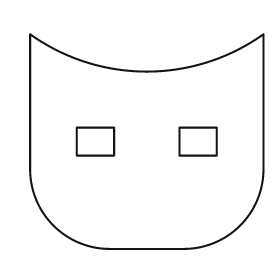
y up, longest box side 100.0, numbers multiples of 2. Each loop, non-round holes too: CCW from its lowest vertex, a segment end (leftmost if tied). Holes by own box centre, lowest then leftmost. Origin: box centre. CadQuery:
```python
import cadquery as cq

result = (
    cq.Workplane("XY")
    .moveTo(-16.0, -46.0)
    .lineTo(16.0, -46.0)
    .threePointArc((40.0, -36.0), (50.0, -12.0))
    .lineTo(50.0, 46.0)
    .threePointArc((0.0, 30.0), (-50.0, 46.0))
    .lineTo(-50.0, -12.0)
    .threePointArc((-40.0, -36.0), (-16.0, -46.0))
    .close()
    .moveTo(-30.0, -6.0)
    .lineTo(-14.0, -6.0)
    .lineTo(-14.0, 6.0)
    .lineTo(-30.0, 6.0)
    .close()
    .moveTo(14.0, -6.0)
    .lineTo(30.0, -6.0)
    .lineTo(30.0, 6.0)
    .lineTo(14.0, 6.0)
    .close()
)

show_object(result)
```